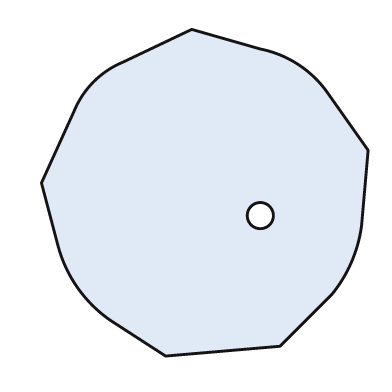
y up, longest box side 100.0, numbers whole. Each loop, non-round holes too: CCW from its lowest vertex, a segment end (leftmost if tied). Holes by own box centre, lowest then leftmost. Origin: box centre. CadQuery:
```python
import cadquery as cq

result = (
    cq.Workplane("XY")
    .moveTo(-12.0, -50.0)
    .lineTo(23.0, -47.0)
    .lineTo(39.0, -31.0)
    .threePointArc((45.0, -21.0), (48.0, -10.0))
    .lineTo(50.0, 13.0)
    .lineTo(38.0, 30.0)
    .threePointArc((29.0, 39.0), (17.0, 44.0))
    .lineTo(-4.0, 50.0)
    .lineTo(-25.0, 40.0)
    .threePointArc((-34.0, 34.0), (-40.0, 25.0))
    .lineTo(-50.0, 3.0)
    .lineTo(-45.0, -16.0)
    .threePointArc((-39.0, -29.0), (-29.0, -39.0))
    .close()
    .moveTo(17.0, -7.0)
    .circle(4.0)
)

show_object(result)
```